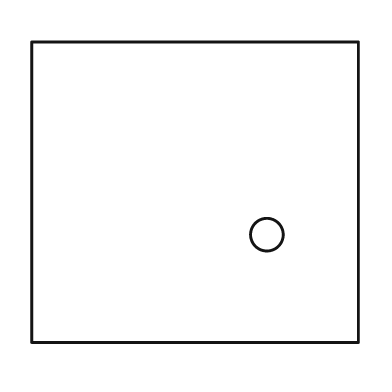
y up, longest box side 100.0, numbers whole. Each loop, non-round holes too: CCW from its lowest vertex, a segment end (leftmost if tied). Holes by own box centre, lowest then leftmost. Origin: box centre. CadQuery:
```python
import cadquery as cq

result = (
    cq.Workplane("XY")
    .moveTo(-50.0, -46.0)
    .lineTo(50.0, -46.0)
    .lineTo(50.0, 46.0)
    .lineTo(-50.0, 46.0)
    .close()
    .moveTo(22.0, -13.0)
    .circle(5.0)
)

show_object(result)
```